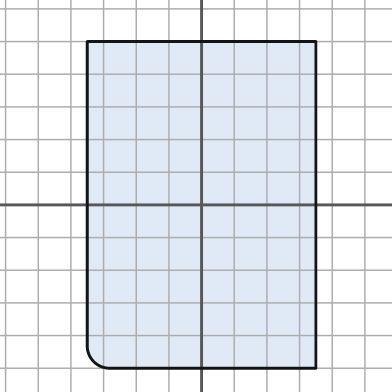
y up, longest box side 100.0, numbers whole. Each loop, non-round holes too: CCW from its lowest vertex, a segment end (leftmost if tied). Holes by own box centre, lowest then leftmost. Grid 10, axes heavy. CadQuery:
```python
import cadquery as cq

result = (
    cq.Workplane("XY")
    .moveTo(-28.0, -50.0)
    .lineTo(35.0, -50.0)
    .lineTo(35.0, 50.0)
    .lineTo(-35.0, 50.0)
    .lineTo(-35.0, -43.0)
    .threePointArc((-33.0, -48.0), (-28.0, -50.0))
    .close()
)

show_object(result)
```